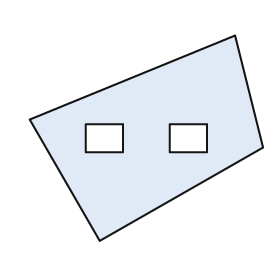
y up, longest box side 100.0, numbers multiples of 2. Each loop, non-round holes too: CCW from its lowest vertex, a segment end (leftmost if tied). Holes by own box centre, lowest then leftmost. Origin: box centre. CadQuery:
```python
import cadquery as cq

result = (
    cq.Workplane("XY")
    .moveTo(-20.0, -44.0)
    .lineTo(50.0, -4.0)
    .lineTo(38.0, 44.0)
    .lineTo(-50.0, 8.0)
    .close()
    .moveTo(-26.0, -6.0)
    .lineTo(-10.0, -6.0)
    .lineTo(-10.0, 6.0)
    .lineTo(-26.0, 6.0)
    .close()
    .moveTo(10.0, -6.0)
    .lineTo(26.0, -6.0)
    .lineTo(26.0, 6.0)
    .lineTo(10.0, 6.0)
    .close()
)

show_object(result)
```